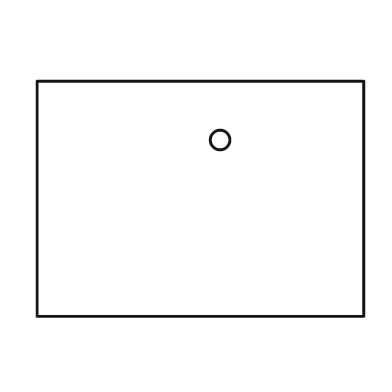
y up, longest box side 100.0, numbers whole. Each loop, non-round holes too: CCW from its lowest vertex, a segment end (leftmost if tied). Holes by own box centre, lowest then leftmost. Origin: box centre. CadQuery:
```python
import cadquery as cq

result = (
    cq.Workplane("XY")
    .moveTo(-50.0, -36.0)
    .lineTo(50.0, -36.0)
    .lineTo(50.0, 36.0)
    .lineTo(-50.0, 36.0)
    .close()
    .moveTo(6.0, 18.0)
    .circle(3.0)
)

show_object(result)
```